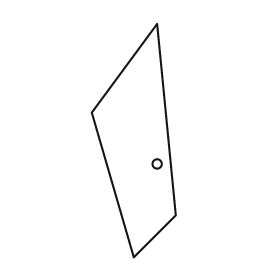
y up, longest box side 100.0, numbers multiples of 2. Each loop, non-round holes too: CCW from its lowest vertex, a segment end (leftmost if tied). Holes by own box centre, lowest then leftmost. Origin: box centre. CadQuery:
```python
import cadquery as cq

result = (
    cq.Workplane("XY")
    .moveTo(0.0, -50.0)
    .lineTo(18.0, -32.0)
    .lineTo(10.0, 50.0)
    .lineTo(-18.0, 12.0)
    .close()
    .moveTo(10.0, -10.0)
    .circle(2.0)
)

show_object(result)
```